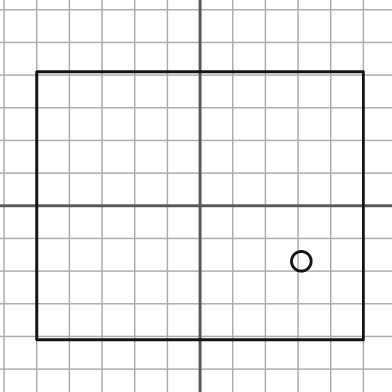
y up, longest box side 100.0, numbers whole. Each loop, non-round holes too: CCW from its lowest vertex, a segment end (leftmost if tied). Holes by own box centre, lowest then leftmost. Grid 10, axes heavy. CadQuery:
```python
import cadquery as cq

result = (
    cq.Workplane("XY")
    .moveTo(-50.0, -41.0)
    .lineTo(50.0, -41.0)
    .lineTo(50.0, 41.0)
    .lineTo(-50.0, 41.0)
    .close()
    .moveTo(31.0, -17.0)
    .circle(3.0)
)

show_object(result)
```